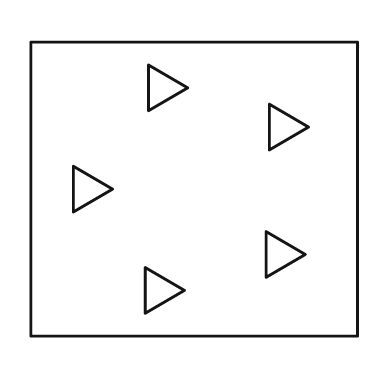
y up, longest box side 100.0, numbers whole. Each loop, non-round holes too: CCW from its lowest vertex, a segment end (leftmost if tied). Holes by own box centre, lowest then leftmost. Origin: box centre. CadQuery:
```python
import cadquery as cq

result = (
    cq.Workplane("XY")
    .moveTo(-50.0, -45.0)
    .lineTo(50.0, -45.0)
    .lineTo(50.0, 45.0)
    .lineTo(-50.0, 45.0)
    .close()
    .moveTo(-15.0, -38.0)
    .lineTo(-3.0, -31.0)
    .lineTo(-15.0, -24.0)
    .close()
    .moveTo(22.0, -27.0)
    .lineTo(34.0, -20.0)
    .lineTo(22.0, -13.0)
    .close()
    .moveTo(-37.0, -7.0)
    .lineTo(-25.0, 0.0)
    .lineTo(-37.0, 7.0)
    .close()
    .moveTo(23.0, 12.0)
    .lineTo(35.0, 19.0)
    .lineTo(23.0, 26.0)
    .close()
    .moveTo(-14.0, 24.0)
    .lineTo(-2.0, 31.0)
    .lineTo(-14.0, 38.0)
    .close()
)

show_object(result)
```